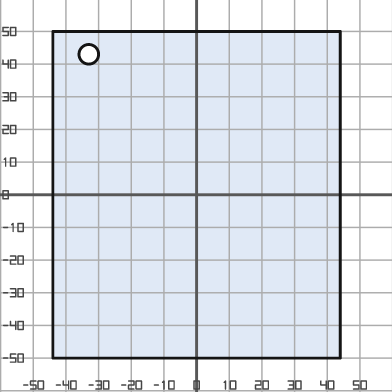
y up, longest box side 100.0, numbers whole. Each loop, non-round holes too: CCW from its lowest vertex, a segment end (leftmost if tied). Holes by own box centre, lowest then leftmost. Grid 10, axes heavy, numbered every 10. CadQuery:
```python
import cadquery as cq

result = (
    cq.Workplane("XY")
    .moveTo(-44.0, -50.0)
    .lineTo(44.0, -50.0)
    .lineTo(44.0, 50.0)
    .lineTo(-44.0, 50.0)
    .close()
    .moveTo(-33.0, 43.0)
    .circle(3.0)
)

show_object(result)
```